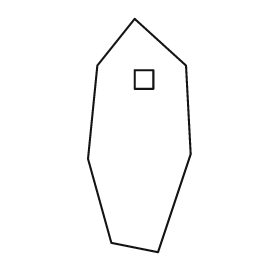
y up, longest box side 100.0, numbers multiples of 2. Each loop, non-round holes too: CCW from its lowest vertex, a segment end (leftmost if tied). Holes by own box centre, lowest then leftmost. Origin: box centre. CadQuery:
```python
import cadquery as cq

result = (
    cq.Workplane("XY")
    .moveTo(8.0, -50.0)
    .lineTo(22.0, -8.0)
    .lineTo(20.0, 30.0)
    .lineTo(-2.0, 50.0)
    .lineTo(-18.0, 30.0)
    .lineTo(-22.0, -10.0)
    .lineTo(-12.0, -46.0)
    .close()
    .moveTo(-2.0, 20.0)
    .lineTo(6.0, 20.0)
    .lineTo(6.0, 28.0)
    .lineTo(-2.0, 28.0)
    .close()
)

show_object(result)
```